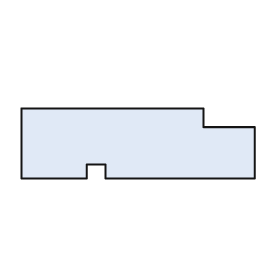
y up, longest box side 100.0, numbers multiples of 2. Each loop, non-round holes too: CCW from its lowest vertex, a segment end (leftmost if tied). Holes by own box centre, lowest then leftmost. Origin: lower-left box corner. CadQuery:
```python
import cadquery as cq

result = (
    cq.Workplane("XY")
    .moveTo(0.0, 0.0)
    .lineTo(28.0, 0.0)
    .lineTo(28.0, 6.0)
    .lineTo(36.0, 6.0)
    .lineTo(36.0, 0.0)
    .lineTo(100.0, 0.0)
    .lineTo(100.0, 22.0)
    .lineTo(78.0, 22.0)
    .lineTo(78.0, 30.0)
    .lineTo(0.0, 30.0)
    .close()
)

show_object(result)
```